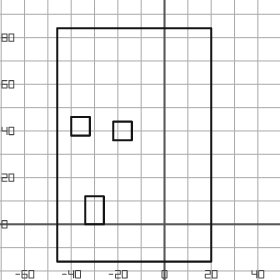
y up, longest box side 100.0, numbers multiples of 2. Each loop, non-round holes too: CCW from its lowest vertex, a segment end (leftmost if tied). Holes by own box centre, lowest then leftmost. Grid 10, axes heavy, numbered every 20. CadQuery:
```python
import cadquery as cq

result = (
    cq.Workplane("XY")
    .moveTo(-46.0, -16.0)
    .lineTo(20.0, -16.0)
    .lineTo(20.0, 84.0)
    .lineTo(-46.0, 84.0)
    .close()
    .moveTo(-34.0, 0.0)
    .lineTo(-26.0, 0.0)
    .lineTo(-26.0, 12.0)
    .lineTo(-34.0, 12.0)
    .close()
    .moveTo(-22.0, 36.0)
    .lineTo(-14.0, 36.0)
    .lineTo(-14.0, 44.0)
    .lineTo(-22.0, 44.0)
    .close()
    .moveTo(-40.0, 38.0)
    .lineTo(-32.0, 38.0)
    .lineTo(-32.0, 46.0)
    .lineTo(-40.0, 46.0)
    .close()
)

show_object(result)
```